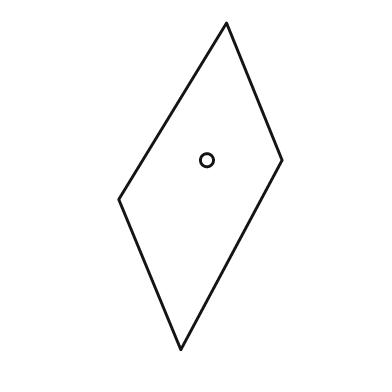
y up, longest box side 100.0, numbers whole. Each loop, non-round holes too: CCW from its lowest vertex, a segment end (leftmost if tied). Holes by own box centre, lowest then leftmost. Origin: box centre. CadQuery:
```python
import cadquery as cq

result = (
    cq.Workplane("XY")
    .moveTo(-6.0, -50.0)
    .lineTo(25.0, 8.0)
    .lineTo(8.0, 50.0)
    .lineTo(-25.0, -4.0)
    .close()
    .moveTo(2.0, 8.0)
    .circle(2.0)
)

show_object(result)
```